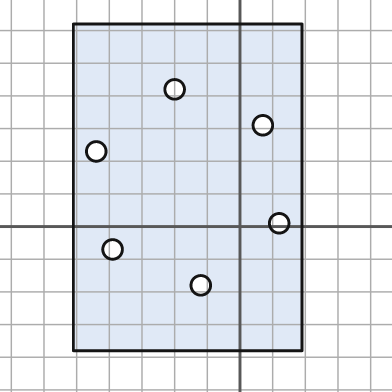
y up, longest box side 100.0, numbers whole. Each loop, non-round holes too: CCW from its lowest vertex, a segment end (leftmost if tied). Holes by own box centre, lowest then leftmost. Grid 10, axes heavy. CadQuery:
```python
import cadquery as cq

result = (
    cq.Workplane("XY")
    .moveTo(-51.0, -38.0)
    .lineTo(19.0, -38.0)
    .lineTo(19.0, 62.0)
    .lineTo(-51.0, 62.0)
    .close()
    .moveTo(-12.0, -18.0)
    .circle(3.0)
    .moveTo(-39.0, -7.0)
    .circle(3.0)
    .moveTo(12.0, 1.0)
    .circle(3.0)
    .moveTo(-44.0, 23.0)
    .circle(3.0)
    .moveTo(7.0, 31.0)
    .circle(3.0)
    .moveTo(-20.0, 42.0)
    .circle(3.0)
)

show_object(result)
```